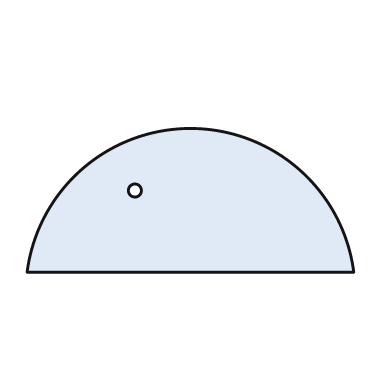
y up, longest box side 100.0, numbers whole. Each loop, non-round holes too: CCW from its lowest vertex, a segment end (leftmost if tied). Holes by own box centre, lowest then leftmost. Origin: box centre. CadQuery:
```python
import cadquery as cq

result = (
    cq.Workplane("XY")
    .moveTo(-50.0, -22.0)
    .lineTo(50.0, -22.0)
    .threePointArc((0.0, 22.0), (-50.0, -22.0))
    .close()
    .moveTo(-17.0, 3.0)
    .circle(2.0)
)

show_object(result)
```